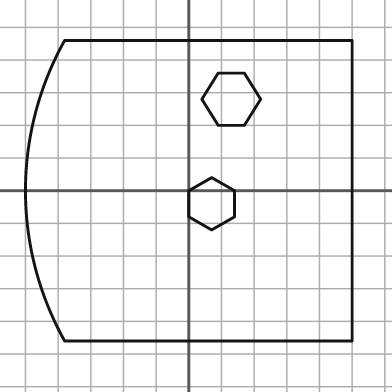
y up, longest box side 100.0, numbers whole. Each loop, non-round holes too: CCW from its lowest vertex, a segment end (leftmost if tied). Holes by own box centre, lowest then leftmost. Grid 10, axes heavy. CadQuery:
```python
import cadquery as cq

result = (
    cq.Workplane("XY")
    .moveTo(-38.0, -46.0)
    .lineTo(50.0, -46.0)
    .lineTo(50.0, 46.0)
    .lineTo(-38.0, 46.0)
    .threePointArc((-50.0, 0.0), (-38.0, -46.0))
    .close()
    .moveTo(7.0, -12.0)
    .lineTo(14.0, -8.0)
    .lineTo(14.0, 0.0)
    .lineTo(7.0, 4.0)
    .lineTo(0.0, 0.0)
    .lineTo(0.0, -8.0)
    .close()
    .moveTo(9.0, 20.0)
    .lineTo(17.0, 20.0)
    .lineTo(22.0, 28.0)
    .lineTo(17.0, 36.0)
    .lineTo(9.0, 36.0)
    .lineTo(4.0, 28.0)
    .close()
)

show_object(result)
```